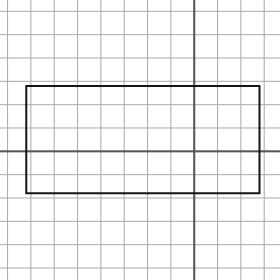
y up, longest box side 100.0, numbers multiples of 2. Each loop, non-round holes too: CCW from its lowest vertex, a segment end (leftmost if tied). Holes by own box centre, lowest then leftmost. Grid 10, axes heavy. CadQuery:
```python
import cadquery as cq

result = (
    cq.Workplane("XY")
    .moveTo(-72.0, -18.0)
    .lineTo(28.0, -18.0)
    .lineTo(28.0, 28.0)
    .lineTo(-72.0, 28.0)
    .close()
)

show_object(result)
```